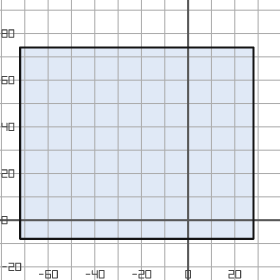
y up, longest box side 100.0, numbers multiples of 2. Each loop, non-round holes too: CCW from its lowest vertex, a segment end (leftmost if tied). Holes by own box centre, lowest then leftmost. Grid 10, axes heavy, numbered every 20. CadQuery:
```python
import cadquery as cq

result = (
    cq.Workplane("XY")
    .moveTo(-72.0, -8.0)
    .lineTo(28.0, -8.0)
    .lineTo(28.0, 74.0)
    .lineTo(-72.0, 74.0)
    .close()
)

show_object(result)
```